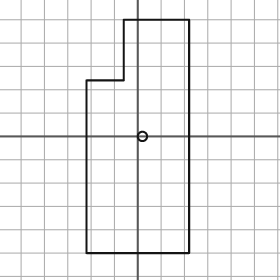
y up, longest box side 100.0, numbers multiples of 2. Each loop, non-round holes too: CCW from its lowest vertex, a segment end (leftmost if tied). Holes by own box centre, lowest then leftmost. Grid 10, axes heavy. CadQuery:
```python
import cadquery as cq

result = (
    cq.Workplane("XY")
    .moveTo(-22.0, -50.0)
    .lineTo(22.0, -50.0)
    .lineTo(22.0, 50.0)
    .lineTo(-6.0, 50.0)
    .lineTo(-6.0, 24.0)
    .lineTo(-22.0, 24.0)
    .close()
    .moveTo(2.0, 0.0)
    .circle(2.0)
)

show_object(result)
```